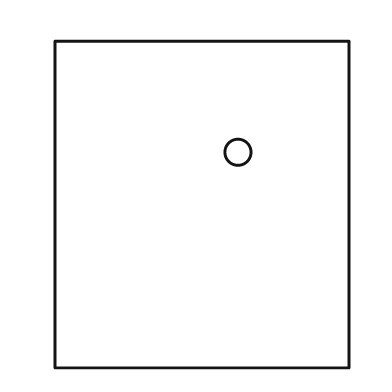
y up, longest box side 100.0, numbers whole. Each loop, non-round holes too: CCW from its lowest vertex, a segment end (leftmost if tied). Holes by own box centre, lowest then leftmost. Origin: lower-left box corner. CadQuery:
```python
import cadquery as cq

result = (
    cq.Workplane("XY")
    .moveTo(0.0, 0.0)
    .lineTo(90.0, 0.0)
    .lineTo(90.0, 100.0)
    .lineTo(0.0, 100.0)
    .close()
    .moveTo(56.0, 66.0)
    .circle(4.0)
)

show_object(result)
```